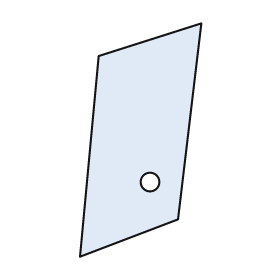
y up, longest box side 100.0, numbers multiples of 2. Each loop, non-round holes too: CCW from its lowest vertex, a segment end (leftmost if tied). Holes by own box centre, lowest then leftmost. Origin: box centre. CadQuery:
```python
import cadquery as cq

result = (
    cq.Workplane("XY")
    .moveTo(-26.0, -50.0)
    .lineTo(16.0, -34.0)
    .lineTo(26.0, 50.0)
    .lineTo(-18.0, 36.0)
    .close()
    .moveTo(4.0, -18.0)
    .circle(4.0)
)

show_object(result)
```